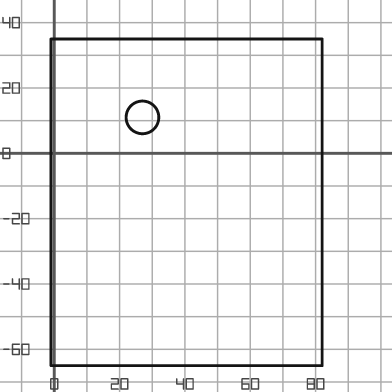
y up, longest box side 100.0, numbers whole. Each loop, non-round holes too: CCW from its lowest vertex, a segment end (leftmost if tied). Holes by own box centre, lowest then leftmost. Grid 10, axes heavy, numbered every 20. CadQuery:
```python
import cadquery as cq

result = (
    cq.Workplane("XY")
    .moveTo(-1.0, -65.0)
    .lineTo(82.0, -65.0)
    .lineTo(82.0, 35.0)
    .lineTo(-1.0, 35.0)
    .close()
    .moveTo(27.0, 11.0)
    .circle(5.0)
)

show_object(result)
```